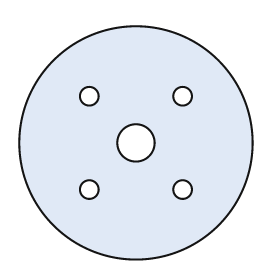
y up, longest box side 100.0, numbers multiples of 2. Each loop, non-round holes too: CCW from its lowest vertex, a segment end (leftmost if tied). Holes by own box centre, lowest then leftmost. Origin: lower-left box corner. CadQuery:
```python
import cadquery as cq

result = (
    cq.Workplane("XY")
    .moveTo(50.0, 50.0)
    .circle(50.0)
    .moveTo(30.0, 30.0)
    .circle(4.0)
    .moveTo(70.0, 30.0)
    .circle(4.0)
    .moveTo(50.0, 50.0)
    .circle(8.0)
    .moveTo(30.0, 70.0)
    .circle(4.0)
    .moveTo(70.0, 70.0)
    .circle(4.0)
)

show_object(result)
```